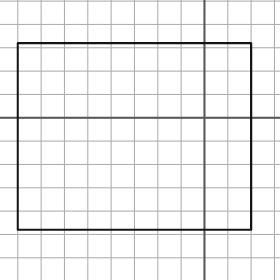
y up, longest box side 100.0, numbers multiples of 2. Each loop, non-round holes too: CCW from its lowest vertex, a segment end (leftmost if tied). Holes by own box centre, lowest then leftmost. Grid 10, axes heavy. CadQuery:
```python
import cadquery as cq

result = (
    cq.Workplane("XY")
    .moveTo(-80.0, -48.0)
    .lineTo(20.0, -48.0)
    .lineTo(20.0, 32.0)
    .lineTo(-80.0, 32.0)
    .close()
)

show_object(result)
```